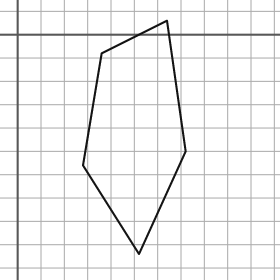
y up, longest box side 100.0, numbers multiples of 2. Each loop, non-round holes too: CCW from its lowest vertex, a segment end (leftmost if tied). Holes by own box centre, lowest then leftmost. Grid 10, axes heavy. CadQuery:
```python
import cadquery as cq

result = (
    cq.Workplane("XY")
    .moveTo(52.0, -94.0)
    .lineTo(72.0, -50.0)
    .lineTo(64.0, 6.0)
    .lineTo(36.0, -8.0)
    .lineTo(28.0, -56.0)
    .close()
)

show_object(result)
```